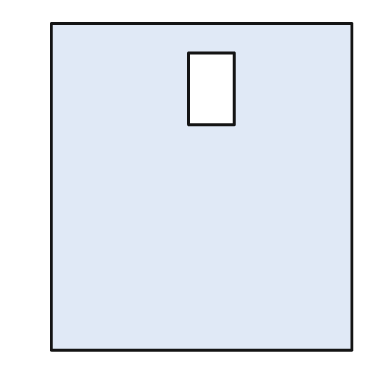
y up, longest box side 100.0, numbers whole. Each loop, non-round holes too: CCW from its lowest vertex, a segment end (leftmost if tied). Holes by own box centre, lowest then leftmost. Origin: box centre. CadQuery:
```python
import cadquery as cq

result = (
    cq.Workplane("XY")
    .moveTo(-46.0, -50.0)
    .lineTo(46.0, -50.0)
    .lineTo(46.0, 50.0)
    .lineTo(-46.0, 50.0)
    .close()
    .moveTo(-4.0, 19.0)
    .lineTo(10.0, 19.0)
    .lineTo(10.0, 41.0)
    .lineTo(-4.0, 41.0)
    .close()
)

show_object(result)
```